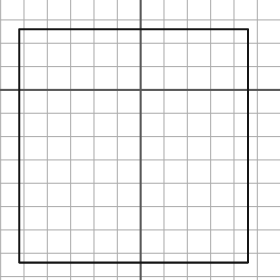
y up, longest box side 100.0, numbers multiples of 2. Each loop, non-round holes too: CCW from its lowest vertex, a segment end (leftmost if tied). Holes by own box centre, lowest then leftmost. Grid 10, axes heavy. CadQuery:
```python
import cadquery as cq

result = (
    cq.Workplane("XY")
    .moveTo(-52.0, -74.0)
    .lineTo(46.0, -74.0)
    .lineTo(46.0, 26.0)
    .lineTo(-52.0, 26.0)
    .close()
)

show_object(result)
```